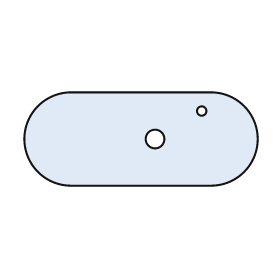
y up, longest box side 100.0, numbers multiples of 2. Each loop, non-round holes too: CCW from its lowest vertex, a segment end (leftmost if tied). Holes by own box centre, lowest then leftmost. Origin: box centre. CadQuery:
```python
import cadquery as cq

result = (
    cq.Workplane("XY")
    .moveTo(-30.0, -20.0)
    .lineTo(30.0, -20.0)
    .threePointArc((50.0, 0.0), (30.0, 20.0))
    .lineTo(-30.0, 20.0)
    .threePointArc((-50.0, 0.0), (-30.0, -20.0))
    .close()
    .moveTo(6.0, 0.0)
    .circle(4.0)
    .moveTo(26.0, 12.0)
    .circle(2.0)
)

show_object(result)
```